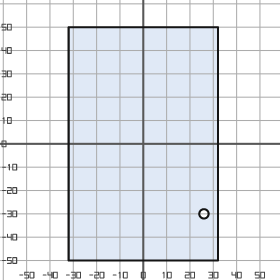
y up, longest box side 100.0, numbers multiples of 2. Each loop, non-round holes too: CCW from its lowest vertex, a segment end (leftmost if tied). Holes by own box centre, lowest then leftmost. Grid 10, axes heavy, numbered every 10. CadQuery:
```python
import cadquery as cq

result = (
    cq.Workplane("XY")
    .moveTo(-32.0, -50.0)
    .lineTo(32.0, -50.0)
    .lineTo(32.0, 50.0)
    .lineTo(-32.0, 50.0)
    .close()
    .moveTo(26.0, -30.0)
    .circle(2.0)
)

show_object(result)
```